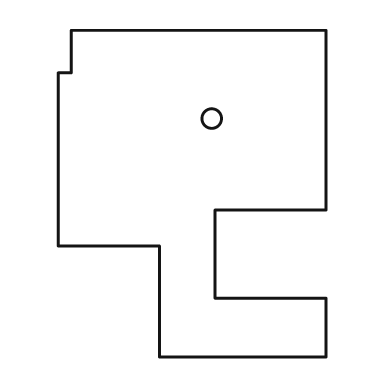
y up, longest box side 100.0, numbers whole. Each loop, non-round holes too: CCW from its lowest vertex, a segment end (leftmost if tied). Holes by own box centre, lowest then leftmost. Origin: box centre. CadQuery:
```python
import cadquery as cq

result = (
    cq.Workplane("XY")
    .moveTo(-10.0, -50.0)
    .lineTo(41.0, -50.0)
    .lineTo(41.0, -32.0)
    .lineTo(7.0, -32.0)
    .lineTo(7.0, -5.0)
    .lineTo(41.0, -5.0)
    .lineTo(41.0, 50.0)
    .lineTo(-37.0, 50.0)
    .lineTo(-37.0, 37.0)
    .lineTo(-41.0, 37.0)
    .lineTo(-41.0, -16.0)
    .lineTo(-10.0, -16.0)
    .close()
    .moveTo(6.0, 23.0)
    .circle(3.0)
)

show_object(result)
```